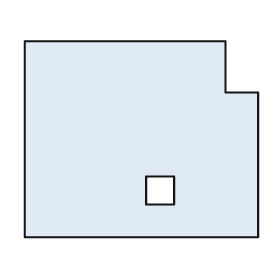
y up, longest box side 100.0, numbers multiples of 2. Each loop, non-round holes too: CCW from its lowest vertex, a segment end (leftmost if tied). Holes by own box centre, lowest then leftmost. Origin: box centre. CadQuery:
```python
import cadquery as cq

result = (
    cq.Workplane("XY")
    .moveTo(-50.0, -42.0)
    .lineTo(50.0, -42.0)
    .lineTo(50.0, 20.0)
    .lineTo(36.0, 20.0)
    .lineTo(36.0, 42.0)
    .lineTo(-50.0, 42.0)
    .close()
    .moveTo(2.0, -28.0)
    .lineTo(14.0, -28.0)
    .lineTo(14.0, -16.0)
    .lineTo(2.0, -16.0)
    .close()
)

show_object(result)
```